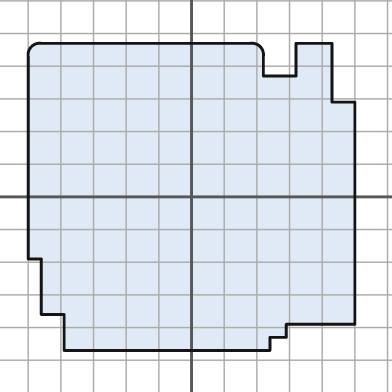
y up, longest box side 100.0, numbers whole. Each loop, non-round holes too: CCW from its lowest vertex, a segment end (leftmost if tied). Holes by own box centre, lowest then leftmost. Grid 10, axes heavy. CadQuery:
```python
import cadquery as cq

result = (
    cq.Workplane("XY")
    .moveTo(-39.0, -47.0)
    .lineTo(24.0, -47.0)
    .lineTo(24.0, -43.0)
    .lineTo(29.0, -43.0)
    .lineTo(29.0, -39.0)
    .lineTo(50.0, -39.0)
    .lineTo(50.0, 29.0)
    .lineTo(43.0, 29.0)
    .lineTo(43.0, 47.0)
    .lineTo(32.0, 47.0)
    .lineTo(32.0, 37.0)
    .lineTo(22.0, 37.0)
    .lineTo(22.0, 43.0)
    .threePointArc((21.0, 46.0), (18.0, 47.0))
    .lineTo(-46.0, 47.0)
    .threePointArc((-49.0, 46.0), (-50.0, 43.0))
    .lineTo(-50.0, -19.0)
    .lineTo(-46.0, -19.0)
    .lineTo(-46.0, -36.0)
    .lineTo(-39.0, -36.0)
    .close()
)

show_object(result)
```